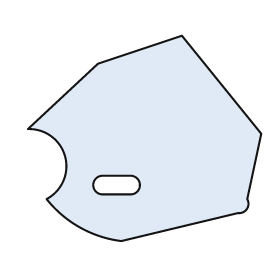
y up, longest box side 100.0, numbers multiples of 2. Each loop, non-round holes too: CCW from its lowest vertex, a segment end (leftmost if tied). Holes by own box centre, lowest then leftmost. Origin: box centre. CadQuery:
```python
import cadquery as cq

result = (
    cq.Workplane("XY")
    .moveTo(-10.0, -44.0)
    .lineTo(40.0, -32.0)
    .threePointArc((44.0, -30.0), (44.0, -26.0))
    .lineTo(50.0, 2.0)
    .lineTo(16.0, 44.0)
    .lineTo(-20.0, 32.0)
    .lineTo(-50.0, 4.0)
    .threePointArc((-34.0, -8.0), (-42.0, -26.0))
    .threePointArc((-28.0, -38.0), (-10.0, -44.0))
    .close()
    .moveTo(-18.0, -24.0)
    .lineTo(-6.0, -24.0)
    .threePointArc((-2.0, -20.0), (-6.0, -16.0))
    .lineTo(-18.0, -16.0)
    .threePointArc((-22.0, -20.0), (-18.0, -24.0))
    .close()
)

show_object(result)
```